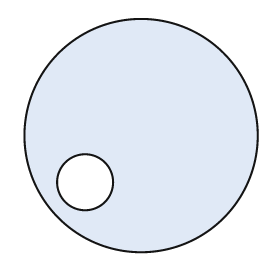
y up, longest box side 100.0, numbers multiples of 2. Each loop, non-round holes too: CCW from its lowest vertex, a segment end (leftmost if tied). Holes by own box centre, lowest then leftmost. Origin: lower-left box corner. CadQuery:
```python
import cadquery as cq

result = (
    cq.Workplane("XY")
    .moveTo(50.0, 50.0)
    .circle(50.0)
    .moveTo(26.0, 30.0)
    .circle(12.0)
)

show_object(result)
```